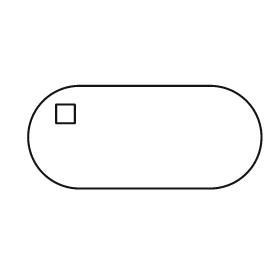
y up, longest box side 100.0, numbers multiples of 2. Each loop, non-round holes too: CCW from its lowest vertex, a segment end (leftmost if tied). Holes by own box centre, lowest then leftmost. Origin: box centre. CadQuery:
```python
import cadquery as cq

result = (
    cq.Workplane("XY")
    .moveTo(-28.0, -22.0)
    .lineTo(28.0, -22.0)
    .threePointArc((50.0, 0.0), (28.0, 22.0))
    .lineTo(-28.0, 22.0)
    .threePointArc((-50.0, 0.0), (-28.0, -22.0))
    .close()
    .moveTo(-38.0, 6.0)
    .lineTo(-30.0, 6.0)
    .lineTo(-30.0, 14.0)
    .lineTo(-38.0, 14.0)
    .close()
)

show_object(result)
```